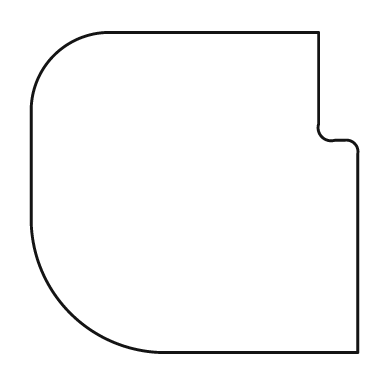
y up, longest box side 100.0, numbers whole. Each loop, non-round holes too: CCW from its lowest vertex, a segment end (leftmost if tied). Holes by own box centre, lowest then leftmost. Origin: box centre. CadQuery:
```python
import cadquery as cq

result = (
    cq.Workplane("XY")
    .moveTo(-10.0, -49.0)
    .lineTo(50.0, -49.0)
    .lineTo(50.0, 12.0)
    .threePointArc((49.0, 15.0), (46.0, 16.0))
    .lineTo(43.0, 16.0)
    .threePointArc((39.0, 17.0), (38.0, 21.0))
    .lineTo(38.0, 49.0)
    .lineTo(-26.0, 49.0)
    .threePointArc((-43.0, 42.0), (-50.0, 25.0))
    .lineTo(-50.0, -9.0)
    .threePointArc((-38.0, -37.0), (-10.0, -49.0))
    .close()
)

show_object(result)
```